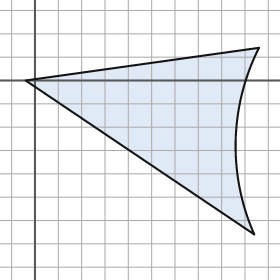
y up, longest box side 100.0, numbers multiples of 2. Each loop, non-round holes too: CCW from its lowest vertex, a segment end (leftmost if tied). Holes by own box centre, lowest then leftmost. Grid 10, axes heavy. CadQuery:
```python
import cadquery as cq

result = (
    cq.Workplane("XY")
    .moveTo(94.0, -66.0)
    .threePointArc((86.0, -26.0), (96.0, 14.0))
    .lineTo(-4.0, 0.0)
    .close()
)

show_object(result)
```